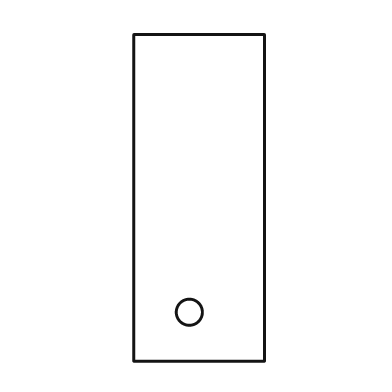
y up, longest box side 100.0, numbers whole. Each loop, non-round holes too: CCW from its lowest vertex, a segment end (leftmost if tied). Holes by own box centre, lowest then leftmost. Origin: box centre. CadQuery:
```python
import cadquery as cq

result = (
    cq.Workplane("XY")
    .moveTo(-20.0, -50.0)
    .lineTo(20.0, -50.0)
    .lineTo(20.0, 50.0)
    .lineTo(-20.0, 50.0)
    .close()
    .moveTo(-3.0, -35.0)
    .circle(4.0)
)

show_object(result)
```